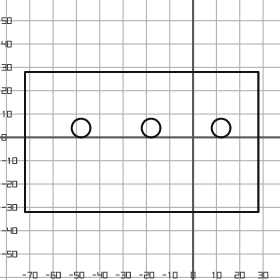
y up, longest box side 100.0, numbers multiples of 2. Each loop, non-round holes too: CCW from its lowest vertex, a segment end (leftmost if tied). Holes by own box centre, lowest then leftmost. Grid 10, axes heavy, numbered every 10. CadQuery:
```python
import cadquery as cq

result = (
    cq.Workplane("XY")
    .moveTo(-72.0, -32.0)
    .lineTo(28.0, -32.0)
    .lineTo(28.0, 28.0)
    .lineTo(-72.0, 28.0)
    .close()
    .moveTo(-48.0, 4.0)
    .circle(4.0)
    .moveTo(-18.0, 4.0)
    .circle(4.0)
    .moveTo(12.0, 4.0)
    .circle(4.0)
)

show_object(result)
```